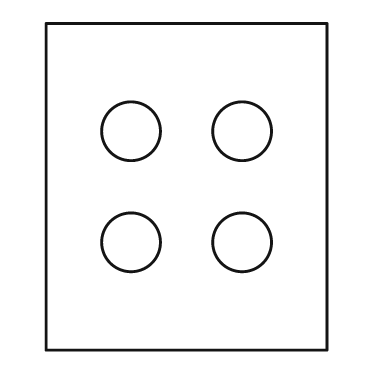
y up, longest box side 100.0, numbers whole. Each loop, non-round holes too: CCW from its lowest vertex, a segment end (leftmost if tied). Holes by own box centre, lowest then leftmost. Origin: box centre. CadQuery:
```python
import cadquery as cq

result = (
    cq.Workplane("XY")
    .moveTo(-43.0, -50.0)
    .lineTo(43.0, -50.0)
    .lineTo(43.0, 50.0)
    .lineTo(-43.0, 50.0)
    .close()
    .moveTo(-17.0, -17.0)
    .circle(9.0)
    .moveTo(17.0, -17.0)
    .circle(9.0)
    .moveTo(-17.0, 17.0)
    .circle(9.0)
    .moveTo(17.0, 17.0)
    .circle(9.0)
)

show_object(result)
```